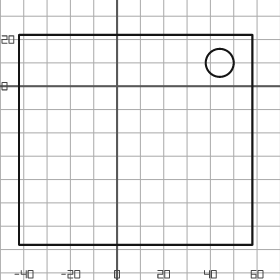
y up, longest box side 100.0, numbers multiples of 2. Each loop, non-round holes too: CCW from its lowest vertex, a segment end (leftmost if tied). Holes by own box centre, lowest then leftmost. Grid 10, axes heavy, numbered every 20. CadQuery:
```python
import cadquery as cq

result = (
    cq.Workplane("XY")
    .moveTo(-42.0, -68.0)
    .lineTo(58.0, -68.0)
    .lineTo(58.0, 22.0)
    .lineTo(-42.0, 22.0)
    .close()
    .moveTo(44.0, 10.0)
    .circle(6.0)
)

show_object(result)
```